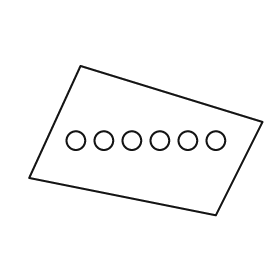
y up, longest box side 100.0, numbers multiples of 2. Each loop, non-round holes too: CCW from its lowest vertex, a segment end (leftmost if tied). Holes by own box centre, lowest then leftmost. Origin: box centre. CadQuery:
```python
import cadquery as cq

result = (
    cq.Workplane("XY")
    .moveTo(30.0, -32.0)
    .lineTo(50.0, 8.0)
    .lineTo(-28.0, 32.0)
    .lineTo(-50.0, -16.0)
    .close()
    .moveTo(-30.0, 0.0)
    .circle(4.0)
    .moveTo(-18.0, 0.0)
    .circle(4.0)
    .moveTo(-6.0, 0.0)
    .circle(4.0)
    .moveTo(6.0, 0.0)
    .circle(4.0)
    .moveTo(18.0, 0.0)
    .circle(4.0)
    .moveTo(30.0, 0.0)
    .circle(4.0)
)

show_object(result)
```